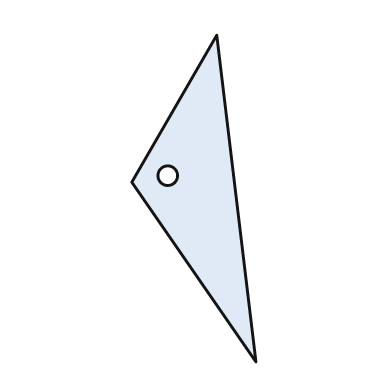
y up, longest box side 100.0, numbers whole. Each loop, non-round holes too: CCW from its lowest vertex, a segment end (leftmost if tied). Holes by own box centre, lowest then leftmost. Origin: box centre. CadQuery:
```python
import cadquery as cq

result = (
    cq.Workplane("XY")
    .moveTo(19.0, -50.0)
    .lineTo(7.0, 50.0)
    .lineTo(-19.0, 5.0)
    .close()
    .moveTo(-8.0, 7.0)
    .circle(3.0)
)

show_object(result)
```